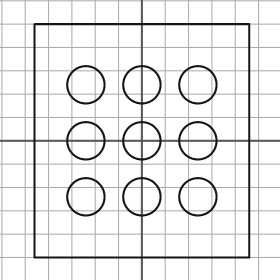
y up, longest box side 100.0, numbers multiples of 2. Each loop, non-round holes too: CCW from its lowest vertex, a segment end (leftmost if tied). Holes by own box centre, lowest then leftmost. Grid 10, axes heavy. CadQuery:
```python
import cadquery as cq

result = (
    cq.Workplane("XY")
    .moveTo(-46.0, -50.0)
    .lineTo(46.0, -50.0)
    .lineTo(46.0, 50.0)
    .lineTo(-46.0, 50.0)
    .close()
    .moveTo(-24.0, -24.0)
    .circle(8.0)
    .moveTo(0.0, -24.0)
    .circle(8.0)
    .moveTo(24.0, -24.0)
    .circle(8.0)
    .moveTo(-24.0, 0.0)
    .circle(8.0)
    .moveTo(0.0, 0.0)
    .circle(8.0)
    .moveTo(24.0, 0.0)
    .circle(8.0)
    .moveTo(-24.0, 24.0)
    .circle(8.0)
    .moveTo(0.0, 24.0)
    .circle(8.0)
    .moveTo(24.0, 24.0)
    .circle(8.0)
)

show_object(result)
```